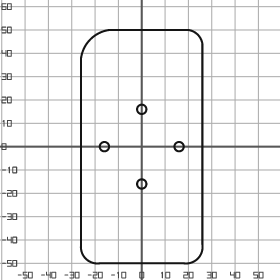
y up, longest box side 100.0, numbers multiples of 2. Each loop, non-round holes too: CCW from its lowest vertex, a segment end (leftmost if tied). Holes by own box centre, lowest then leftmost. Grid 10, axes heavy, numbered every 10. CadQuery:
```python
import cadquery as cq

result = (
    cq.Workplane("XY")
    .moveTo(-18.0, -50.0)
    .lineTo(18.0, -50.0)
    .threePointArc((24.0, -48.0), (26.0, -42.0))
    .lineTo(26.0, 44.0)
    .threePointArc((24.0, 48.0), (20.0, 50.0))
    .lineTo(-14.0, 50.0)
    .threePointArc((-22.0, 46.0), (-26.0, 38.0))
    .lineTo(-26.0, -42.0)
    .threePointArc((-24.0, -48.0), (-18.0, -50.0))
    .close()
    .moveTo(0.0, -16.0)
    .circle(2.0)
    .moveTo(-16.0, 0.0)
    .circle(2.0)
    .moveTo(16.0, 0.0)
    .circle(2.0)
    .moveTo(0.0, 16.0)
    .circle(2.0)
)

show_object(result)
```